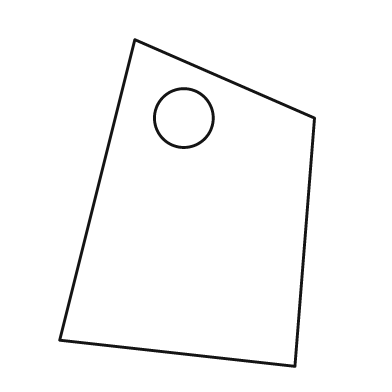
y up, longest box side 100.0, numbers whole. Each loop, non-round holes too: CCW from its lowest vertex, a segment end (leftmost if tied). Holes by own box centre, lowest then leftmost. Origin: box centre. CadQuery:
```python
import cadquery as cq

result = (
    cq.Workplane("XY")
    .moveTo(33.0, -50.0)
    .lineTo(39.0, 26.0)
    .lineTo(-16.0, 50.0)
    .lineTo(-39.0, -42.0)
    .close()
    .moveTo(-1.0, 26.0)
    .circle(9.0)
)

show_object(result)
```